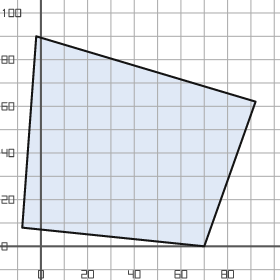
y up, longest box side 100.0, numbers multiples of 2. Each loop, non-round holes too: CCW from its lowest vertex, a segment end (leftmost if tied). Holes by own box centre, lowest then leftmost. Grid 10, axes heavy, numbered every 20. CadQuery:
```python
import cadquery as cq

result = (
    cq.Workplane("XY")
    .moveTo(70.0, 0.0)
    .lineTo(92.0, 62.0)
    .lineTo(-2.0, 90.0)
    .lineTo(-8.0, 8.0)
    .close()
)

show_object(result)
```